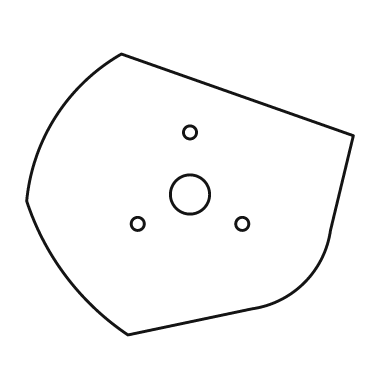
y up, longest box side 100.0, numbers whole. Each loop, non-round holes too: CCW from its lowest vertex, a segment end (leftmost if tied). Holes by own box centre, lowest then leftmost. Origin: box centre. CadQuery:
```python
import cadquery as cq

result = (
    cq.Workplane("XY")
    .moveTo(-19.0, -43.0)
    .lineTo(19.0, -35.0)
    .threePointArc((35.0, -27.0), (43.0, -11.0))
    .lineTo(50.0, 18.0)
    .lineTo(-21.0, 43.0)
    .threePointArc((-41.0, 24.0), (-50.0, -2.0))
    .threePointArc((-38.0, -25.0), (-19.0, -43.0))
    .close()
    .moveTo(-16.0, -9.0)
    .circle(2.0)
    .moveTo(16.0, -9.0)
    .circle(2.0)
    .moveTo(0.0, 0.0)
    .circle(6.0)
    .moveTo(0.0, 19.0)
    .circle(2.0)
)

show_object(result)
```